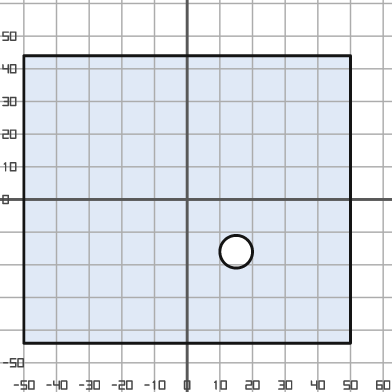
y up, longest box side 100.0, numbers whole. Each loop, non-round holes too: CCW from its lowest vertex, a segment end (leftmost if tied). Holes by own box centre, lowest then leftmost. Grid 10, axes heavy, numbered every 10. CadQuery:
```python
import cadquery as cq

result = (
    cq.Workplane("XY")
    .moveTo(-50.0, -44.0)
    .lineTo(50.0, -44.0)
    .lineTo(50.0, 44.0)
    .lineTo(-50.0, 44.0)
    .close()
    .moveTo(15.0, -16.0)
    .circle(5.0)
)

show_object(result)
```